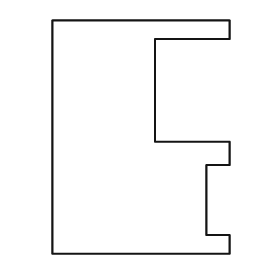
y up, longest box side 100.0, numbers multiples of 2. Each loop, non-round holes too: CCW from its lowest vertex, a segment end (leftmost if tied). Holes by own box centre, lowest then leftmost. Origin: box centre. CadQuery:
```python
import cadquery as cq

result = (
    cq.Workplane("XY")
    .moveTo(-38.0, -50.0)
    .lineTo(38.0, -50.0)
    .lineTo(38.0, -42.0)
    .lineTo(28.0, -42.0)
    .lineTo(28.0, -12.0)
    .lineTo(38.0, -12.0)
    .lineTo(38.0, -2.0)
    .lineTo(6.0, -2.0)
    .lineTo(6.0, 42.0)
    .lineTo(38.0, 42.0)
    .lineTo(38.0, 50.0)
    .lineTo(-38.0, 50.0)
    .close()
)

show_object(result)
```